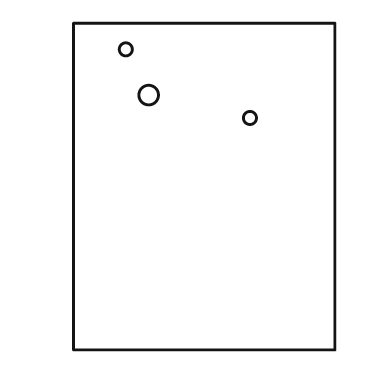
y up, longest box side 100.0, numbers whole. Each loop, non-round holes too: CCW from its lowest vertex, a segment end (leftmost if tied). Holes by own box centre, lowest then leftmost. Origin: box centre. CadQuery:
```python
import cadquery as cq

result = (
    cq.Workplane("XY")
    .moveTo(-40.0, -50.0)
    .lineTo(40.0, -50.0)
    .lineTo(40.0, 50.0)
    .lineTo(-40.0, 50.0)
    .close()
    .moveTo(14.0, 21.0)
    .circle(2.0)
    .moveTo(-17.0, 28.0)
    .circle(3.0)
    .moveTo(-24.0, 42.0)
    .circle(2.0)
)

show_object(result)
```